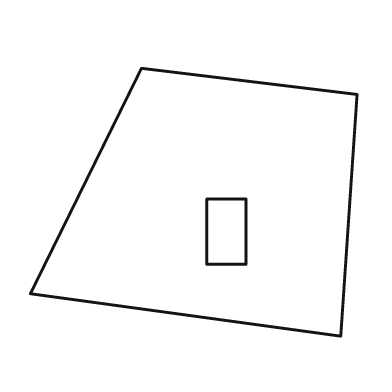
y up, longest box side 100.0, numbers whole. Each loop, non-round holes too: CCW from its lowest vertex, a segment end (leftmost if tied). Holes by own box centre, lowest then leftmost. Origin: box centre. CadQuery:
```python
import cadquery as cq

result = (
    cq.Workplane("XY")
    .moveTo(45.0, -41.0)
    .lineTo(50.0, 33.0)
    .lineTo(-16.0, 41.0)
    .lineTo(-50.0, -28.0)
    .close()
    .moveTo(4.0, -19.0)
    .lineTo(16.0, -19.0)
    .lineTo(16.0, 1.0)
    .lineTo(4.0, 1.0)
    .close()
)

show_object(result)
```